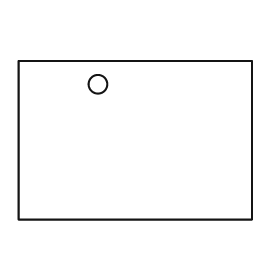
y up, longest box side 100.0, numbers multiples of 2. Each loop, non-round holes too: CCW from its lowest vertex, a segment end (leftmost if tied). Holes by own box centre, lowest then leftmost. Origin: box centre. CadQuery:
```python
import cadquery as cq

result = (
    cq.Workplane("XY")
    .moveTo(-50.0, -34.0)
    .lineTo(50.0, -34.0)
    .lineTo(50.0, 34.0)
    .lineTo(-50.0, 34.0)
    .close()
    .moveTo(-16.0, 24.0)
    .circle(4.0)
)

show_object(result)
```